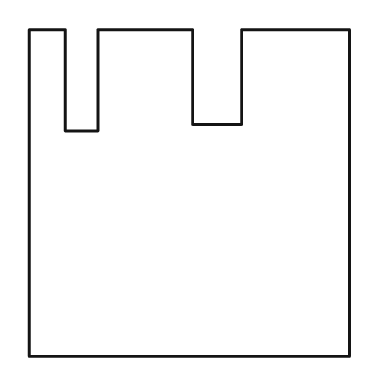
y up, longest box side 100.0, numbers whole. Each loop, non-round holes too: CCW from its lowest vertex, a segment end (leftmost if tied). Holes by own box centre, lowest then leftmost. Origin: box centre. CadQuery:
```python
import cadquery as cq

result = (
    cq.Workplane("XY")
    .moveTo(-49.0, -50.0)
    .lineTo(49.0, -50.0)
    .lineTo(49.0, 50.0)
    .lineTo(16.0, 50.0)
    .lineTo(16.0, 21.0)
    .lineTo(1.0, 21.0)
    .lineTo(1.0, 50.0)
    .lineTo(-28.0, 50.0)
    .lineTo(-28.0, 19.0)
    .lineTo(-38.0, 19.0)
    .lineTo(-38.0, 50.0)
    .lineTo(-49.0, 50.0)
    .close()
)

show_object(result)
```